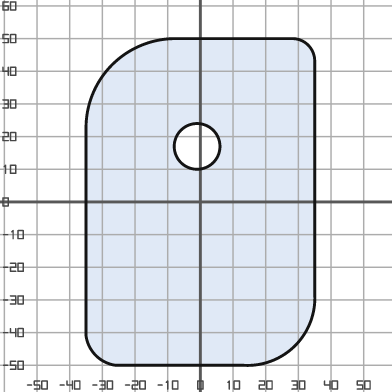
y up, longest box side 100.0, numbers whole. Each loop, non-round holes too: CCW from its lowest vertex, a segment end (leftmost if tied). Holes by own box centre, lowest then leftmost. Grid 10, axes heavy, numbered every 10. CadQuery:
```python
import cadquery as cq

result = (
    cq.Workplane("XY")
    .moveTo(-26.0, -50.0)
    .lineTo(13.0, -50.0)
    .threePointArc((29.0, -44.0), (35.0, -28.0))
    .lineTo(35.0, 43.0)
    .threePointArc((33.0, 48.0), (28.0, 50.0))
    .lineTo(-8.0, 50.0)
    .threePointArc((-27.0, 42.0), (-35.0, 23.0))
    .lineTo(-35.0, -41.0)
    .threePointArc((-32.0, -47.0), (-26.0, -50.0))
    .close()
    .moveTo(-1.0, 17.0)
    .circle(7.0)
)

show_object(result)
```